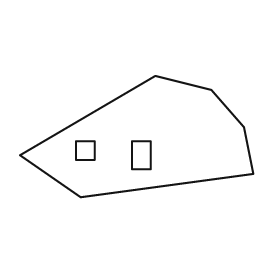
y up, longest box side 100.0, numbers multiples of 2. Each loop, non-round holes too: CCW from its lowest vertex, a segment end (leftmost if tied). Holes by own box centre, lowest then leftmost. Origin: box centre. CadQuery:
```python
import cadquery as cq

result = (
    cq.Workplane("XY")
    .moveTo(-24.0, -26.0)
    .lineTo(50.0, -16.0)
    .lineTo(46.0, 4.0)
    .lineTo(32.0, 20.0)
    .lineTo(8.0, 26.0)
    .lineTo(-50.0, -8.0)
    .close()
    .moveTo(-2.0, -14.0)
    .lineTo(6.0, -14.0)
    .lineTo(6.0, -2.0)
    .lineTo(-2.0, -2.0)
    .close()
    .moveTo(-26.0, -10.0)
    .lineTo(-18.0, -10.0)
    .lineTo(-18.0, -2.0)
    .lineTo(-26.0, -2.0)
    .close()
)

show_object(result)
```